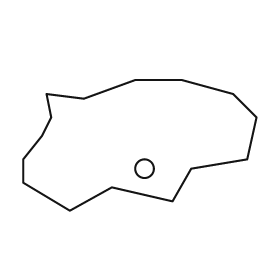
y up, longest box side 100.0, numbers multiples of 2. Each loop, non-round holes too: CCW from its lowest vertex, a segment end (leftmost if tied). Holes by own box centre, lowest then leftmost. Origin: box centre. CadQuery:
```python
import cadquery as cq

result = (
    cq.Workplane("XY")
    .moveTo(-30.0, -28.0)
    .lineTo(-12.0, -18.0)
    .lineTo(14.0, -24.0)
    .lineTo(22.0, -10.0)
    .lineTo(46.0, -6.0)
    .lineTo(50.0, 12.0)
    .lineTo(40.0, 22.0)
    .lineTo(18.0, 28.0)
    .lineTo(-2.0, 28.0)
    .lineTo(-24.0, 20.0)
    .lineTo(-40.0, 22.0)
    .lineTo(-38.0, 12.0)
    .lineTo(-42.0, 4.0)
    .lineTo(-50.0, -6.0)
    .lineTo(-50.0, -16.0)
    .close()
    .moveTo(2.0, -10.0)
    .circle(4.0)
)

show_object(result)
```